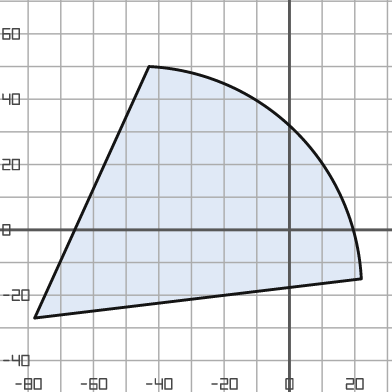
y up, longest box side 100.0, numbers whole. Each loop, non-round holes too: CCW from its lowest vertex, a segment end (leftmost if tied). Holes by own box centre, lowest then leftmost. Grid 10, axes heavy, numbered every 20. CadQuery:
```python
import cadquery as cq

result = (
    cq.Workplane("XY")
    .moveTo(-78.0, -27.0)
    .lineTo(22.0, -15.0)
    .threePointArc((2.0, 30.0), (-43.0, 50.0))
    .close()
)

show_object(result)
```